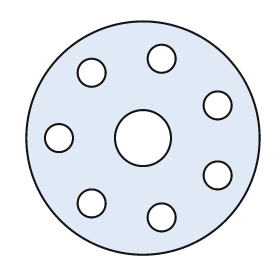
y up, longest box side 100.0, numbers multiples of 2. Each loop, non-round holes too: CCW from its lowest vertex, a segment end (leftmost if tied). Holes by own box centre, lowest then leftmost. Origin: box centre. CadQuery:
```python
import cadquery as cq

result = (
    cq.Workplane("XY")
    .moveTo(0.0, 0.0)
    .circle(50.0)
    .moveTo(8.0, -34.0)
    .circle(6.0)
    .moveTo(-22.0, -28.0)
    .circle(6.0)
    .moveTo(32.0, -16.0)
    .circle(6.0)
    .moveTo(-36.0, 0.0)
    .circle(6.0)
    .moveTo(0.0, 0.0)
    .circle(12.0)
    .moveTo(32.0, 14.0)
    .circle(6.0)
    .moveTo(-22.0, 28.0)
    .circle(6.0)
    .moveTo(8.0, 34.0)
    .circle(6.0)
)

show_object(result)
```